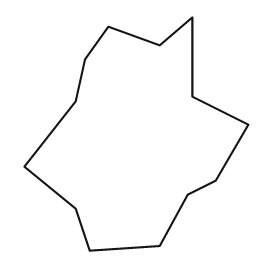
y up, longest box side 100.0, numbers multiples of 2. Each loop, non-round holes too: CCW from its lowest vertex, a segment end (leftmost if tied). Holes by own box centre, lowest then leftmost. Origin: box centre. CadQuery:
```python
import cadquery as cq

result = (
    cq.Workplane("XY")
    .moveTo(-20.0, -50.0)
    .lineTo(10.0, -48.0)
    .lineTo(22.0, -26.0)
    .lineTo(34.0, -20.0)
    .lineTo(48.0, 4.0)
    .lineTo(24.0, 16.0)
    .lineTo(24.0, 50.0)
    .lineTo(10.0, 38.0)
    .lineTo(-12.0, 46.0)
    .lineTo(-22.0, 32.0)
    .lineTo(-26.0, 14.0)
    .lineTo(-48.0, -14.0)
    .lineTo(-26.0, -32.0)
    .close()
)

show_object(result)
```